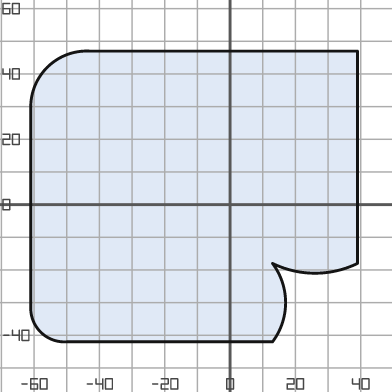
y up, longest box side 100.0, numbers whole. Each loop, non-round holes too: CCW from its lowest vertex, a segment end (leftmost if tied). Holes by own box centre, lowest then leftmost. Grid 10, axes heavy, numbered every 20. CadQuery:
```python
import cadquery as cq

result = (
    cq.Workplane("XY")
    .moveTo(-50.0, -42.0)
    .lineTo(13.0, -42.0)
    .threePointArc((17.0, -30.0), (13.0, -18.0))
    .threePointArc((26.0, -21.0), (39.0, -18.0))
    .lineTo(39.0, 47.0)
    .lineTo(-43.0, 47.0)
    .threePointArc((-56.0, 42.0), (-61.0, 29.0))
    .lineTo(-61.0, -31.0)
    .threePointArc((-58.0, -39.0), (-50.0, -42.0))
    .close()
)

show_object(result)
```